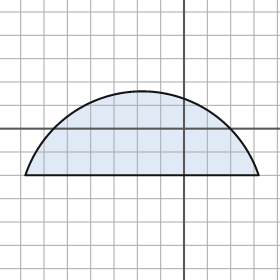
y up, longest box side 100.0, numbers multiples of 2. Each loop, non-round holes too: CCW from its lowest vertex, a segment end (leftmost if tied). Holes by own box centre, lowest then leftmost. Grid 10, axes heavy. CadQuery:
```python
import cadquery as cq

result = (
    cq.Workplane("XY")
    .moveTo(-68.0, -20.0)
    .lineTo(32.0, -20.0)
    .threePointArc((-18.0, 16.0), (-68.0, -20.0))
    .close()
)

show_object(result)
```